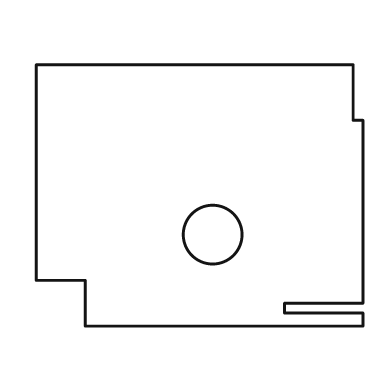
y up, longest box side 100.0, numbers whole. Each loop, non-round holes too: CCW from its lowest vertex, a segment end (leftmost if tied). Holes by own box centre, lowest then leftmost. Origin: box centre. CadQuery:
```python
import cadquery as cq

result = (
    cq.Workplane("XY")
    .moveTo(-35.0, -40.0)
    .lineTo(50.0, -40.0)
    .lineTo(50.0, -36.0)
    .lineTo(26.0, -36.0)
    .lineTo(26.0, -33.0)
    .lineTo(50.0, -33.0)
    .lineTo(50.0, 23.0)
    .lineTo(47.0, 23.0)
    .lineTo(47.0, 40.0)
    .lineTo(-50.0, 40.0)
    .lineTo(-50.0, -26.0)
    .lineTo(-35.0, -26.0)
    .close()
    .moveTo(4.0, -12.0)
    .circle(9.0)
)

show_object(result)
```